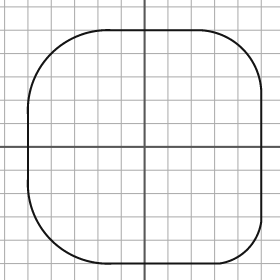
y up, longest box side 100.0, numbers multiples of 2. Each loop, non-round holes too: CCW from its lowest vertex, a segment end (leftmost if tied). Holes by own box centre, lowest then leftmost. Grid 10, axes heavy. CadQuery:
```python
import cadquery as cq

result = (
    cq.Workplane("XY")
    .moveTo(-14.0, -50.0)
    .lineTo(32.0, -50.0)
    .threePointArc((44.0, -44.0), (50.0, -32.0))
    .lineTo(50.0, 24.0)
    .threePointArc((42.0, 42.0), (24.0, 50.0))
    .lineTo(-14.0, 50.0)
    .threePointArc((-40.0, 40.0), (-50.0, 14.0))
    .lineTo(-50.0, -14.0)
    .threePointArc((-40.0, -40.0), (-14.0, -50.0))
    .close()
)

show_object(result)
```